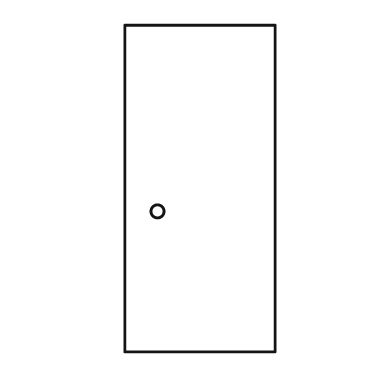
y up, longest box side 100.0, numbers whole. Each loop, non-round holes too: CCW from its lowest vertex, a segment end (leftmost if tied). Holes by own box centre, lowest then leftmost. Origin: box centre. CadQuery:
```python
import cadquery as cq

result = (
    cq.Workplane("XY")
    .moveTo(-23.0, -50.0)
    .lineTo(23.0, -50.0)
    .lineTo(23.0, 50.0)
    .lineTo(-23.0, 50.0)
    .close()
    .moveTo(-13.0, -7.0)
    .circle(2.0)
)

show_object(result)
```